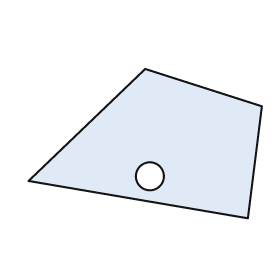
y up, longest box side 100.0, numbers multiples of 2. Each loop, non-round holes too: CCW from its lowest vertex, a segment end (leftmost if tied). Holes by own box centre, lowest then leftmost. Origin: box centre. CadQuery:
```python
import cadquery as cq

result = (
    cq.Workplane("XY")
    .moveTo(44.0, -32.0)
    .lineTo(50.0, 16.0)
    .lineTo(0.0, 32.0)
    .lineTo(-50.0, -16.0)
    .close()
    .moveTo(2.0, -14.0)
    .circle(6.0)
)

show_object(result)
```